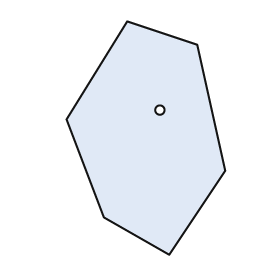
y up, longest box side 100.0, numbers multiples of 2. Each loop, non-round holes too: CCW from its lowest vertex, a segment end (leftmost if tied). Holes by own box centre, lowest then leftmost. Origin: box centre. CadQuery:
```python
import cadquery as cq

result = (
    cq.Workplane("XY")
    .moveTo(10.0, -50.0)
    .lineTo(34.0, -14.0)
    .lineTo(22.0, 40.0)
    .lineTo(-8.0, 50.0)
    .lineTo(-34.0, 8.0)
    .lineTo(-18.0, -34.0)
    .close()
    .moveTo(6.0, 12.0)
    .circle(2.0)
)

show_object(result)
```